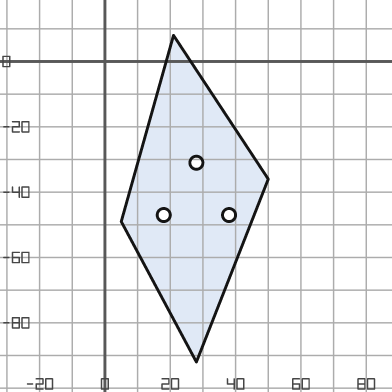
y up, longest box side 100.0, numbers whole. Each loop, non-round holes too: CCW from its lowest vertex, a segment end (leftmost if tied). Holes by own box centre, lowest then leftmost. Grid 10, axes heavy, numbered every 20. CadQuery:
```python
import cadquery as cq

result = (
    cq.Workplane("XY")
    .moveTo(28.0, -92.0)
    .lineTo(50.0, -36.0)
    .lineTo(21.0, 8.0)
    .lineTo(5.0, -49.0)
    .close()
    .moveTo(18.0, -47.0)
    .circle(2.0)
    .moveTo(38.0, -47.0)
    .circle(2.0)
    .moveTo(28.0, -31.0)
    .circle(2.0)
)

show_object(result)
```